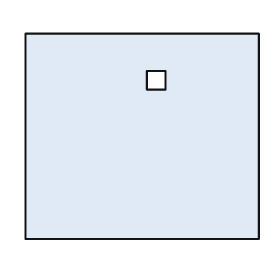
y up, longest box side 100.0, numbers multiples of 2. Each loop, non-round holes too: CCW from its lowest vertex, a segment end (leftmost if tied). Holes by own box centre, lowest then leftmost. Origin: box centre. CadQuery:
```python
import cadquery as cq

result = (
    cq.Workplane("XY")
    .moveTo(-50.0, -44.0)
    .lineTo(50.0, -44.0)
    .lineTo(50.0, 44.0)
    .lineTo(-50.0, 44.0)
    .close()
    .moveTo(2.0, 20.0)
    .lineTo(10.0, 20.0)
    .lineTo(10.0, 28.0)
    .lineTo(2.0, 28.0)
    .close()
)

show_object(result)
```